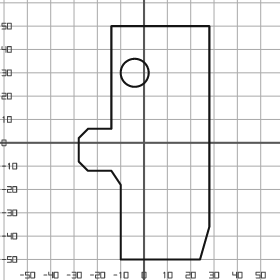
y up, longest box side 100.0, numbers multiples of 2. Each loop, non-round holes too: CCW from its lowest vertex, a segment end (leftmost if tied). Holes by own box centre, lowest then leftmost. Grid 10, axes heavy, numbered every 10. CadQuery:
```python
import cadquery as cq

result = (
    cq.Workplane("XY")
    .moveTo(-10.0, -50.0)
    .lineTo(24.0, -50.0)
    .lineTo(28.0, -36.0)
    .lineTo(28.0, 50.0)
    .lineTo(-14.0, 50.0)
    .lineTo(-14.0, 6.0)
    .lineTo(-24.0, 6.0)
    .lineTo(-28.0, 2.0)
    .lineTo(-28.0, -8.0)
    .lineTo(-24.0, -12.0)
    .lineTo(-14.0, -12.0)
    .lineTo(-10.0, -18.0)
    .close()
    .moveTo(-4.0, 30.0)
    .circle(6.0)
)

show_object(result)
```